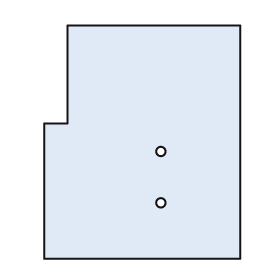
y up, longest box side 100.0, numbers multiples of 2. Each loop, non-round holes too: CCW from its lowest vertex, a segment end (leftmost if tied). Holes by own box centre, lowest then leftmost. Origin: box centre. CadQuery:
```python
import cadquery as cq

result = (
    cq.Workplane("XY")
    .moveTo(-42.0, -50.0)
    .lineTo(42.0, -50.0)
    .lineTo(42.0, 50.0)
    .lineTo(-32.0, 50.0)
    .lineTo(-32.0, 8.0)
    .lineTo(-42.0, 8.0)
    .close()
    .moveTo(8.0, -26.0)
    .circle(2.0)
    .moveTo(8.0, -4.0)
    .circle(2.0)
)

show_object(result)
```